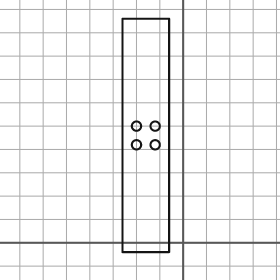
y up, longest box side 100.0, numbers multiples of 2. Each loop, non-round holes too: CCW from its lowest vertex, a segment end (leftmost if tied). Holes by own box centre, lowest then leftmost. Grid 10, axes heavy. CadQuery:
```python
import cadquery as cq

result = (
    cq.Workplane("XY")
    .moveTo(-26.0, -4.0)
    .lineTo(-6.0, -4.0)
    .lineTo(-6.0, 96.0)
    .lineTo(-26.0, 96.0)
    .close()
    .moveTo(-20.0, 42.0)
    .circle(2.0)
    .moveTo(-12.0, 42.0)
    .circle(2.0)
    .moveTo(-20.0, 50.0)
    .circle(2.0)
    .moveTo(-12.0, 50.0)
    .circle(2.0)
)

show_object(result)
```